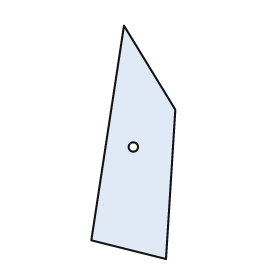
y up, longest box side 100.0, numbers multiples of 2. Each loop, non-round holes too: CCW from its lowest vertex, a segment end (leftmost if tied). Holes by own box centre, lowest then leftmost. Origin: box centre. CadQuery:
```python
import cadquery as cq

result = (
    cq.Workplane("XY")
    .moveTo(14.0, -50.0)
    .lineTo(18.0, 14.0)
    .lineTo(-4.0, 50.0)
    .lineTo(-18.0, -42.0)
    .close()
    .moveTo(0.0, -2.0)
    .circle(2.0)
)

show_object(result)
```